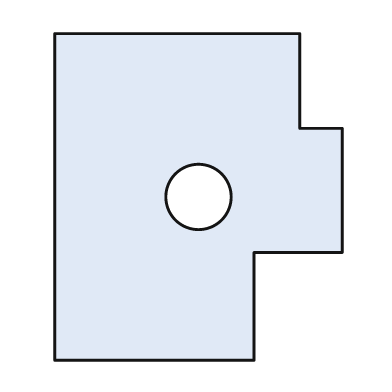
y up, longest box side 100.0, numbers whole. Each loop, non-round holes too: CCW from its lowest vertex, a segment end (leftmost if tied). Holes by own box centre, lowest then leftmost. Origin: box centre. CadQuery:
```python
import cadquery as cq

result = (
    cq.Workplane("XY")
    .moveTo(-44.0, -50.0)
    .lineTo(17.0, -50.0)
    .lineTo(17.0, -17.0)
    .lineTo(44.0, -17.0)
    .lineTo(44.0, 21.0)
    .lineTo(31.0, 21.0)
    .lineTo(31.0, 50.0)
    .lineTo(-44.0, 50.0)
    .close()
    .moveTo(0.0, 0.0)
    .circle(10.0)
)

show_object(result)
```